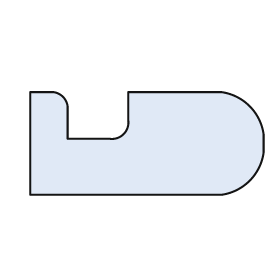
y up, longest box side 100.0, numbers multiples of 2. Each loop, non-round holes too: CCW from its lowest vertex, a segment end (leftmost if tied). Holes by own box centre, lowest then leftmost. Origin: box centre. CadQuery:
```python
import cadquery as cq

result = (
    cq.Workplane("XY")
    .moveTo(-50.0, -22.0)
    .lineTo(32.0, -22.0)
    .threePointArc((44.0, -16.0), (50.0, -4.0))
    .lineTo(50.0, 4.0)
    .threePointArc((44.0, 16.0), (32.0, 22.0))
    .lineTo(-8.0, 22.0)
    .lineTo(-8.0, 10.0)
    .threePointArc((-10.0, 4.0), (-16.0, 2.0))
    .lineTo(-34.0, 2.0)
    .lineTo(-34.0, 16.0)
    .threePointArc((-36.0, 20.0), (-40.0, 22.0))
    .lineTo(-50.0, 22.0)
    .close()
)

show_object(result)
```